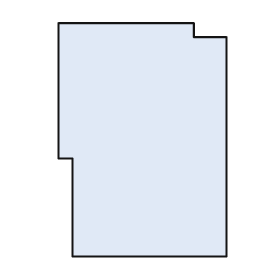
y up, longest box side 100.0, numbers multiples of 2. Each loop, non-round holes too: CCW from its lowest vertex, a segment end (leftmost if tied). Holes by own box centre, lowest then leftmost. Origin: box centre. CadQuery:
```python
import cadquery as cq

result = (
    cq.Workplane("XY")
    .moveTo(-30.0, -50.0)
    .lineTo(36.0, -50.0)
    .lineTo(36.0, 44.0)
    .lineTo(22.0, 44.0)
    .lineTo(22.0, 50.0)
    .lineTo(-36.0, 50.0)
    .lineTo(-36.0, -8.0)
    .lineTo(-30.0, -8.0)
    .close()
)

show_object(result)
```